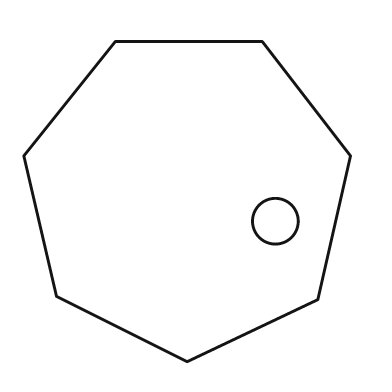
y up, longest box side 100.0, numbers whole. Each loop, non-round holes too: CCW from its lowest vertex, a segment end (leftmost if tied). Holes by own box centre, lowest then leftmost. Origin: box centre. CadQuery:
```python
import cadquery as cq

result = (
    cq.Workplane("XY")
    .moveTo(0.0, -49.0)
    .lineTo(40.0, -30.0)
    .lineTo(50.0, 14.0)
    .lineTo(23.0, 49.0)
    .lineTo(-22.0, 49.0)
    .lineTo(-50.0, 14.0)
    .lineTo(-40.0, -29.0)
    .close()
    .moveTo(27.0, -6.0)
    .circle(7.0)
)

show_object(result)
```